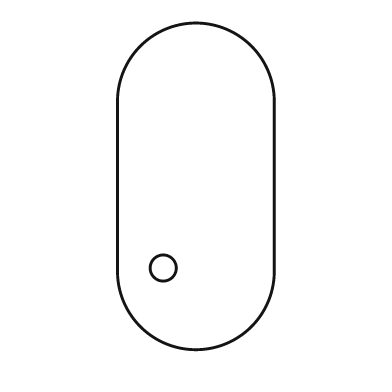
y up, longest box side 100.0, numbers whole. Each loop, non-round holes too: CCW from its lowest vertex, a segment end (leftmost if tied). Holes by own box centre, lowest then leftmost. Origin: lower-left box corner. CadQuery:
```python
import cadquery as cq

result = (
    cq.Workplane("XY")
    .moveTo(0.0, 24.0)
    .threePointArc((24.0, 0.0), (48.0, 24.0))
    .lineTo(48.0, 76.0)
    .threePointArc((24.0, 100.0), (0.0, 76.0))
    .close()
    .moveTo(14.0, 25.0)
    .circle(4.0)
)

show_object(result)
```